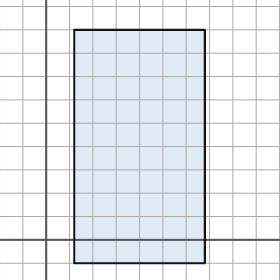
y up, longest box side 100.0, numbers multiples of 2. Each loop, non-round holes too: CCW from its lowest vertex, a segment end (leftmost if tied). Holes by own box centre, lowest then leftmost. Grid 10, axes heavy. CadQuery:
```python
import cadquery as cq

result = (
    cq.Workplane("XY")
    .moveTo(12.0, -10.0)
    .lineTo(68.0, -10.0)
    .lineTo(68.0, 90.0)
    .lineTo(12.0, 90.0)
    .close()
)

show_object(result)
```